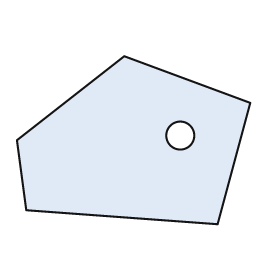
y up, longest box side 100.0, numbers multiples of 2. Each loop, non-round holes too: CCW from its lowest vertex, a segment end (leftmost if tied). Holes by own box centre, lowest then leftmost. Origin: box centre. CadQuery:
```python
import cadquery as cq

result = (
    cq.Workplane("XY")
    .moveTo(36.0, -36.0)
    .lineTo(50.0, 16.0)
    .lineTo(-4.0, 36.0)
    .lineTo(-50.0, 0.0)
    .lineTo(-46.0, -30.0)
    .close()
    .moveTo(20.0, 2.0)
    .circle(6.0)
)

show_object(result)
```